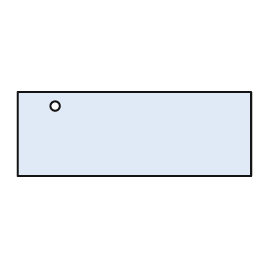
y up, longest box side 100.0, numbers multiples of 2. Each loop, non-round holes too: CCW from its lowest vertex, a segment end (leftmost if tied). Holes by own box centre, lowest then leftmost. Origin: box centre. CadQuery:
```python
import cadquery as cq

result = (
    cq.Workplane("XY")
    .moveTo(-50.0, -18.0)
    .lineTo(50.0, -18.0)
    .lineTo(50.0, 18.0)
    .lineTo(-50.0, 18.0)
    .close()
    .moveTo(-34.0, 12.0)
    .circle(2.0)
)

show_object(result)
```